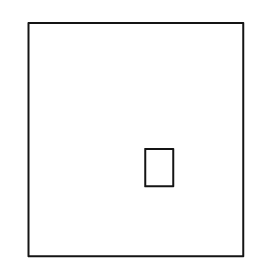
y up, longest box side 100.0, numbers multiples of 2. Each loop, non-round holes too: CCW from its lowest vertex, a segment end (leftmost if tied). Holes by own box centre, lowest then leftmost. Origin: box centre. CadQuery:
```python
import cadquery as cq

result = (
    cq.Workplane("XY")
    .moveTo(-46.0, -50.0)
    .lineTo(46.0, -50.0)
    .lineTo(46.0, 50.0)
    .lineTo(-46.0, 50.0)
    .close()
    .moveTo(4.0, -20.0)
    .lineTo(16.0, -20.0)
    .lineTo(16.0, -4.0)
    .lineTo(4.0, -4.0)
    .close()
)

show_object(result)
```